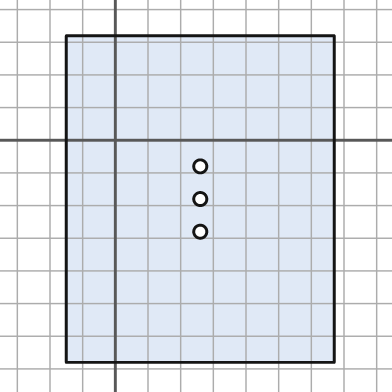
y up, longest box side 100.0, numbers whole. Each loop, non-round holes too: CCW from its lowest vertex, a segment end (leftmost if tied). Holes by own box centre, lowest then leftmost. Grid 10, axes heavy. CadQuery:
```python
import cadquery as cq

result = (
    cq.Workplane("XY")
    .moveTo(-15.0, -68.0)
    .lineTo(67.0, -68.0)
    .lineTo(67.0, 32.0)
    .lineTo(-15.0, 32.0)
    .close()
    .moveTo(26.0, -28.0)
    .circle(2.0)
    .moveTo(26.0, -18.0)
    .circle(2.0)
    .moveTo(26.0, -8.0)
    .circle(2.0)
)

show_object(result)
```